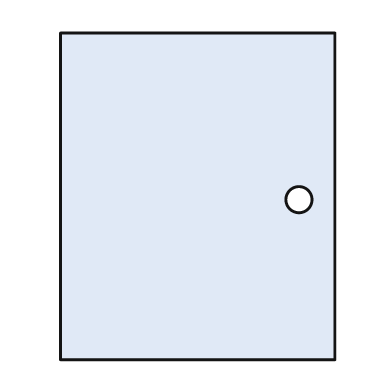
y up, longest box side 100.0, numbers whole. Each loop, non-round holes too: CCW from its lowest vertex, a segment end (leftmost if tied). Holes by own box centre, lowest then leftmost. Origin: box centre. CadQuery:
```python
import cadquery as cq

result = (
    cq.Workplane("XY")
    .moveTo(-42.0, -50.0)
    .lineTo(42.0, -50.0)
    .lineTo(42.0, 50.0)
    .lineTo(-42.0, 50.0)
    .close()
    .moveTo(31.0, -1.0)
    .circle(4.0)
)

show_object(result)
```